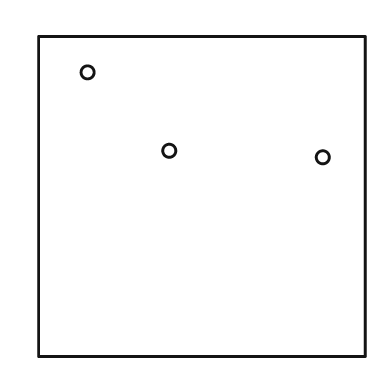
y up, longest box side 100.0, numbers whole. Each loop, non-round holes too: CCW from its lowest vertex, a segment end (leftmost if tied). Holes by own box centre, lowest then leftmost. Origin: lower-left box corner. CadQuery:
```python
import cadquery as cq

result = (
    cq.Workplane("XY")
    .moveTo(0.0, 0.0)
    .lineTo(100.0, 0.0)
    .lineTo(100.0, 98.0)
    .lineTo(0.0, 98.0)
    .close()
    .moveTo(87.0, 61.0)
    .circle(2.0)
    .moveTo(40.0, 63.0)
    .circle(2.0)
    .moveTo(15.0, 87.0)
    .circle(2.0)
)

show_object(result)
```